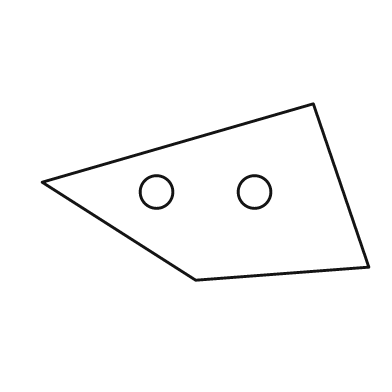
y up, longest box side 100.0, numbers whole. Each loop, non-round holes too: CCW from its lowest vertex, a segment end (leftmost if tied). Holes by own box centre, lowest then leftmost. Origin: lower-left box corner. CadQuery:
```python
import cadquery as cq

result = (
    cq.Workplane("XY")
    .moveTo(47.0, 0.0)
    .lineTo(100.0, 4.0)
    .lineTo(83.0, 54.0)
    .lineTo(0.0, 30.0)
    .close()
    .moveTo(35.0, 27.0)
    .circle(5.0)
    .moveTo(65.0, 27.0)
    .circle(5.0)
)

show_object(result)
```